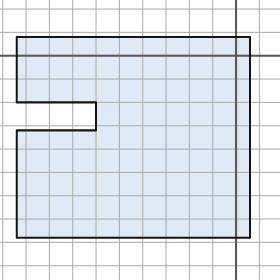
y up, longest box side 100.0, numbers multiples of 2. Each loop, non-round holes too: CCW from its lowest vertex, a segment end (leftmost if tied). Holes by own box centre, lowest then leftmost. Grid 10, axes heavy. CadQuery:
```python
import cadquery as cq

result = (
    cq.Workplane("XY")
    .moveTo(-94.0, -78.0)
    .lineTo(6.0, -78.0)
    .lineTo(6.0, 8.0)
    .lineTo(-94.0, 8.0)
    .lineTo(-94.0, -20.0)
    .lineTo(-60.0, -20.0)
    .lineTo(-60.0, -32.0)
    .lineTo(-94.0, -32.0)
    .close()
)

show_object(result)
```